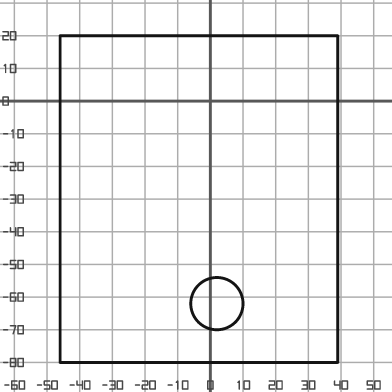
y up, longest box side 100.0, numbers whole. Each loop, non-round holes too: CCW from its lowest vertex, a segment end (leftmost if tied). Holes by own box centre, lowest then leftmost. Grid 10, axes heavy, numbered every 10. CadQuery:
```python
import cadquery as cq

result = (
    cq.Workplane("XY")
    .moveTo(-46.0, -80.0)
    .lineTo(39.0, -80.0)
    .lineTo(39.0, 20.0)
    .lineTo(-46.0, 20.0)
    .close()
    .moveTo(2.0, -62.0)
    .circle(8.0)
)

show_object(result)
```